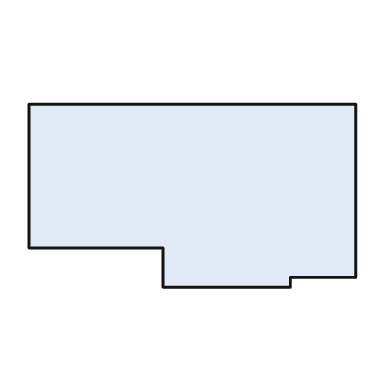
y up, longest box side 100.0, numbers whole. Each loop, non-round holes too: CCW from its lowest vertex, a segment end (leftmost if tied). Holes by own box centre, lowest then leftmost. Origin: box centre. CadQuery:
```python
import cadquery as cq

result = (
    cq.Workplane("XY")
    .moveTo(-9.0, -28.0)
    .lineTo(30.0, -28.0)
    .lineTo(30.0, -25.0)
    .lineTo(50.0, -25.0)
    .lineTo(50.0, 28.0)
    .lineTo(-50.0, 28.0)
    .lineTo(-50.0, -16.0)
    .lineTo(-9.0, -16.0)
    .close()
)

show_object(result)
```